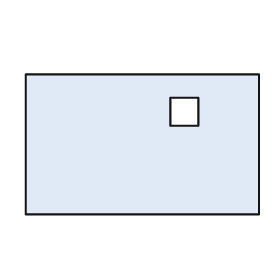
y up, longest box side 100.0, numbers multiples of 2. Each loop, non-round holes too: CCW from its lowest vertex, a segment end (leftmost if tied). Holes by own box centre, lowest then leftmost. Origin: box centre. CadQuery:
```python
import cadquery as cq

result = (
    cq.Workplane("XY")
    .moveTo(-50.0, -30.0)
    .lineTo(50.0, -30.0)
    .lineTo(50.0, 30.0)
    .lineTo(-50.0, 30.0)
    .close()
    .moveTo(12.0, 8.0)
    .lineTo(24.0, 8.0)
    .lineTo(24.0, 20.0)
    .lineTo(12.0, 20.0)
    .close()
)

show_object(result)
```